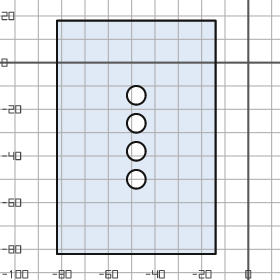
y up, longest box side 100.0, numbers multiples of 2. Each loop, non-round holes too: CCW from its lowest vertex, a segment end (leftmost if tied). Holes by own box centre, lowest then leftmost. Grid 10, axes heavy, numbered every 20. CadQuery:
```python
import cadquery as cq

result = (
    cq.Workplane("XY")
    .moveTo(-82.0, -82.0)
    .lineTo(-14.0, -82.0)
    .lineTo(-14.0, 18.0)
    .lineTo(-82.0, 18.0)
    .close()
    .moveTo(-48.0, -50.0)
    .circle(4.0)
    .moveTo(-48.0, -38.0)
    .circle(4.0)
    .moveTo(-48.0, -26.0)
    .circle(4.0)
    .moveTo(-48.0, -14.0)
    .circle(4.0)
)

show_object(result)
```